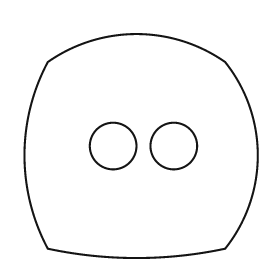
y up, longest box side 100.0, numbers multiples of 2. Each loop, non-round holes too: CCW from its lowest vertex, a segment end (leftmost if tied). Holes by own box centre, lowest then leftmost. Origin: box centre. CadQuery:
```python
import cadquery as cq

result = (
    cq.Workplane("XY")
    .moveTo(-40.0, -44.0)
    .threePointArc((-2.0, -48.0), (36.0, -44.0))
    .threePointArc((50.0, -4.0), (36.0, 36.0))
    .threePointArc((-2.0, 48.0), (-40.0, 36.0))
    .threePointArc((-50.0, -4.0), (-40.0, -44.0))
    .close()
    .moveTo(-12.0, 0.0)
    .circle(10.0)
    .moveTo(14.0, 0.0)
    .circle(10.0)
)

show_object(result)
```